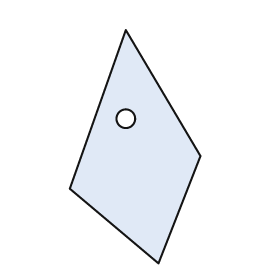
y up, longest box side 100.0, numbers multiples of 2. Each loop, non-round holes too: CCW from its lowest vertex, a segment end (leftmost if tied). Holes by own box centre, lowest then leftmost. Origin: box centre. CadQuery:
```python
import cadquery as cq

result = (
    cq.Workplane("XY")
    .moveTo(10.0, -50.0)
    .lineTo(28.0, -4.0)
    .lineTo(-4.0, 50.0)
    .lineTo(-28.0, -18.0)
    .close()
    .moveTo(-4.0, 12.0)
    .circle(4.0)
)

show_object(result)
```